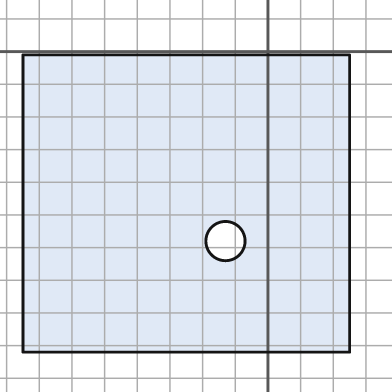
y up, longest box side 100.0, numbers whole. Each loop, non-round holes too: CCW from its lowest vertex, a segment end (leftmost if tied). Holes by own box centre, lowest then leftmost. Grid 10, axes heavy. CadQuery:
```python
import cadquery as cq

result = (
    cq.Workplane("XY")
    .moveTo(-75.0, -92.0)
    .lineTo(25.0, -92.0)
    .lineTo(25.0, -1.0)
    .lineTo(-75.0, -1.0)
    .close()
    .moveTo(-13.0, -58.0)
    .circle(6.0)
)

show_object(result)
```